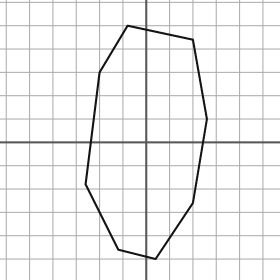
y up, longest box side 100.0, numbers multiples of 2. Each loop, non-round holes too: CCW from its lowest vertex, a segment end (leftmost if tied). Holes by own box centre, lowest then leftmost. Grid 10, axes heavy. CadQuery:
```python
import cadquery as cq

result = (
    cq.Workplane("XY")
    .moveTo(4.0, -50.0)
    .lineTo(20.0, -26.0)
    .lineTo(26.0, 10.0)
    .lineTo(20.0, 44.0)
    .lineTo(-8.0, 50.0)
    .lineTo(-20.0, 30.0)
    .lineTo(-26.0, -18.0)
    .lineTo(-12.0, -46.0)
    .close()
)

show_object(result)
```